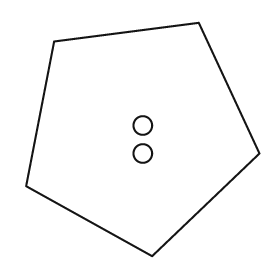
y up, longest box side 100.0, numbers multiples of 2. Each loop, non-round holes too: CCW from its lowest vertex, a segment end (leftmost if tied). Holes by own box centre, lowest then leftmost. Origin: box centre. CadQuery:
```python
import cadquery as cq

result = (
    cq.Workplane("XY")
    .moveTo(4.0, -50.0)
    .lineTo(50.0, -6.0)
    .lineTo(24.0, 50.0)
    .lineTo(-38.0, 42.0)
    .lineTo(-50.0, -20.0)
    .close()
    .moveTo(0.0, -6.0)
    .circle(4.0)
    .moveTo(0.0, 6.0)
    .circle(4.0)
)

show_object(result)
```